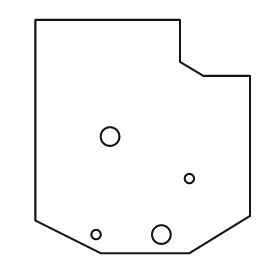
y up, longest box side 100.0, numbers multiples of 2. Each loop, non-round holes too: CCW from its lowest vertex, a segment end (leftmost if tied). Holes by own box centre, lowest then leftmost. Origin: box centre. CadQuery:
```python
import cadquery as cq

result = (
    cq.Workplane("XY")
    .moveTo(-18.0, -50.0)
    .lineTo(20.0, -50.0)
    .lineTo(46.0, -34.0)
    .lineTo(46.0, 26.0)
    .lineTo(26.0, 26.0)
    .lineTo(16.0, 32.0)
    .lineTo(16.0, 50.0)
    .lineTo(-46.0, 50.0)
    .lineTo(-46.0, -36.0)
    .close()
    .moveTo(-20.0, -42.0)
    .circle(2.0)
    .moveTo(8.0, -42.0)
    .circle(4.0)
    .moveTo(20.0, -18.0)
    .circle(2.0)
    .moveTo(-14.0, 0.0)
    .circle(4.0)
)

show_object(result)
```